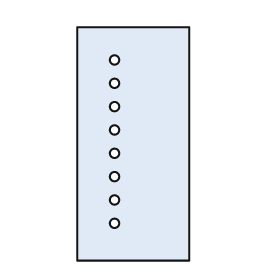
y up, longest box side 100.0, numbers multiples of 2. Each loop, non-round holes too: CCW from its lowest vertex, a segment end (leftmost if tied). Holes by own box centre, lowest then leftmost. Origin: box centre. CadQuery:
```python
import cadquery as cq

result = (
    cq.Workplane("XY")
    .moveTo(-24.0, -50.0)
    .lineTo(24.0, -50.0)
    .lineTo(24.0, 50.0)
    .lineTo(-24.0, 50.0)
    .close()
    .moveTo(-8.0, -34.0)
    .circle(2.0)
    .moveTo(-8.0, -24.0)
    .circle(2.0)
    .moveTo(-8.0, -14.0)
    .circle(2.0)
    .moveTo(-8.0, -4.0)
    .circle(2.0)
    .moveTo(-8.0, 6.0)
    .circle(2.0)
    .moveTo(-8.0, 16.0)
    .circle(2.0)
    .moveTo(-8.0, 26.0)
    .circle(2.0)
    .moveTo(-8.0, 36.0)
    .circle(2.0)
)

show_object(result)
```